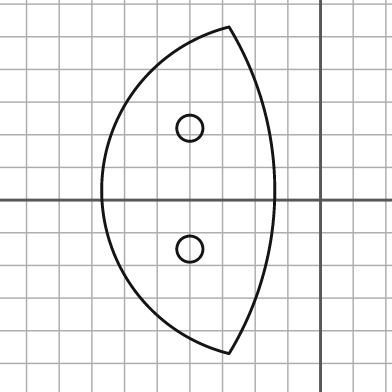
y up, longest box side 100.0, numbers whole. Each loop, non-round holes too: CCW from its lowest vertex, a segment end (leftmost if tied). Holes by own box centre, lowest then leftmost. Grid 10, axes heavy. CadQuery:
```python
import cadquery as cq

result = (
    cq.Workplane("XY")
    .moveTo(-28.0, -47.0)
    .threePointArc((-14.0, 3.0), (-28.0, 53.0))
    .threePointArc((-67.0, 3.0), (-28.0, -47.0))
    .close()
    .moveTo(-40.0, -15.0)
    .circle(4.0)
    .moveTo(-40.0, 22.0)
    .circle(4.0)
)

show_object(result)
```